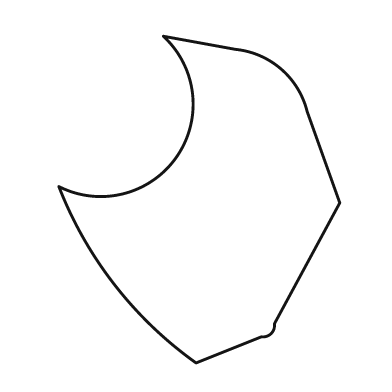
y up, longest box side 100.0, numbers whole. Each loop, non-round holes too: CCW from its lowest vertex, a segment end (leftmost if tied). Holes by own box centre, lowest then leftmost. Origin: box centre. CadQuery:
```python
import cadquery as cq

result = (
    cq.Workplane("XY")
    .moveTo(-1.0, -50.0)
    .lineTo(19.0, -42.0)
    .threePointArc((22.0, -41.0), (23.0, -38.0))
    .lineTo(43.0, -1.0)
    .lineTo(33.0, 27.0)
    .threePointArc((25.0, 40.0), (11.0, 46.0))
    .lineTo(-11.0, 50.0)
    .threePointArc((-7.0, 13.0), (-43.0, 4.0))
    .threePointArc((-26.0, -26.0), (-1.0, -50.0))
    .close()
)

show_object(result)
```